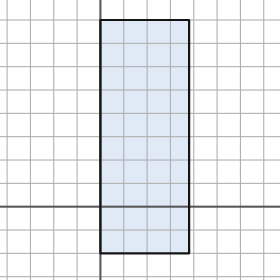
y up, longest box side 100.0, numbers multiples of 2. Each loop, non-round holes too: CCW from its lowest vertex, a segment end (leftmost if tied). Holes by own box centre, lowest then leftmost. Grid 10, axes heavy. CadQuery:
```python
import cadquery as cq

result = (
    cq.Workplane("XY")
    .moveTo(0.0, -20.0)
    .lineTo(38.0, -20.0)
    .lineTo(38.0, 80.0)
    .lineTo(0.0, 80.0)
    .close()
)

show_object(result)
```